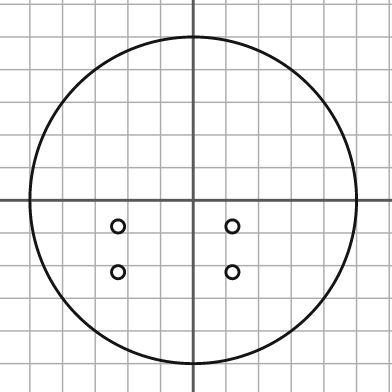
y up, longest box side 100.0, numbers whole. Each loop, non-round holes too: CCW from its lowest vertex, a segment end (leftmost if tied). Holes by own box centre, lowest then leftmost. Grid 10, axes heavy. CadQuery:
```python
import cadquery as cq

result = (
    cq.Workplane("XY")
    .moveTo(0.0, 0.0)
    .circle(50.0)
    .moveTo(-23.0, -22.0)
    .circle(2.0)
    .moveTo(12.0, -22.0)
    .circle(2.0)
    .moveTo(-23.0, -8.0)
    .circle(2.0)
    .moveTo(12.0, -8.0)
    .circle(2.0)
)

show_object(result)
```